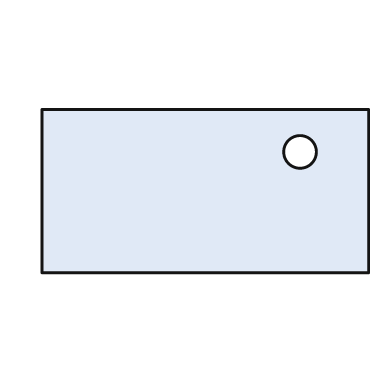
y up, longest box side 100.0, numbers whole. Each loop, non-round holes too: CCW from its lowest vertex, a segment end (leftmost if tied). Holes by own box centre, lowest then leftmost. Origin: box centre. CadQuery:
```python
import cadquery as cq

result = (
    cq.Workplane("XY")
    .moveTo(-50.0, -25.0)
    .lineTo(50.0, -25.0)
    .lineTo(50.0, 25.0)
    .lineTo(-50.0, 25.0)
    .close()
    .moveTo(29.0, 12.0)
    .circle(5.0)
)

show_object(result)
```